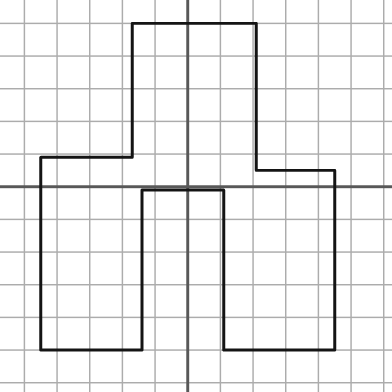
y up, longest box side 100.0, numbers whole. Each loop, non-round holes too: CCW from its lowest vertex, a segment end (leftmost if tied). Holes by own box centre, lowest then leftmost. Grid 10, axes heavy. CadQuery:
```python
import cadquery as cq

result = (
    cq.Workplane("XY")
    .moveTo(-45.0, -50.0)
    .lineTo(-14.0, -50.0)
    .lineTo(-14.0, -1.0)
    .lineTo(11.0, -1.0)
    .lineTo(11.0, -50.0)
    .lineTo(45.0, -50.0)
    .lineTo(45.0, 5.0)
    .lineTo(21.0, 5.0)
    .lineTo(21.0, 50.0)
    .lineTo(-17.0, 50.0)
    .lineTo(-17.0, 9.0)
    .lineTo(-45.0, 9.0)
    .close()
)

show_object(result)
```